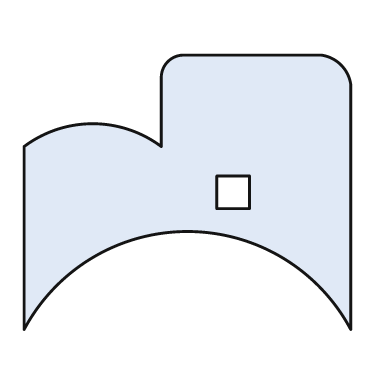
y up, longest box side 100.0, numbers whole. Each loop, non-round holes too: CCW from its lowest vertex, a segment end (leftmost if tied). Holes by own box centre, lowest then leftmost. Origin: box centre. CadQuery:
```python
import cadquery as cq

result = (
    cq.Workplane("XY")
    .moveTo(-50.0, -42.0)
    .threePointArc((0.0, -12.0), (50.0, -42.0))
    .lineTo(50.0, 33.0)
    .threePointArc((47.0, 39.0), (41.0, 42.0))
    .lineTo(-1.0, 42.0)
    .threePointArc((-6.0, 40.0), (-8.0, 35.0))
    .lineTo(-8.0, 14.0)
    .threePointArc((-29.0, 21.0), (-50.0, 14.0))
    .close()
    .moveTo(9.0, -5.0)
    .lineTo(19.0, -5.0)
    .lineTo(19.0, 5.0)
    .lineTo(9.0, 5.0)
    .close()
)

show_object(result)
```